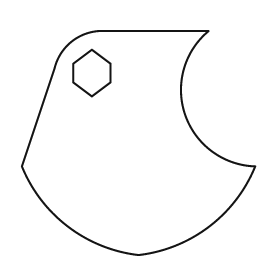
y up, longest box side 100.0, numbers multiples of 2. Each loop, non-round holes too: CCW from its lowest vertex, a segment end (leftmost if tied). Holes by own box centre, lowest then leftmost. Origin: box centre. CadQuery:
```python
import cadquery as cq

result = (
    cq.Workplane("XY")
    .moveTo(0.0, -48.0)
    .threePointArc((30.0, -36.0), (50.0, -10.0))
    .threePointArc((20.0, 12.0), (30.0, 48.0))
    .lineTo(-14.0, 48.0)
    .threePointArc((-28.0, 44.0), (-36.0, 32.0))
    .lineTo(-50.0, -10.0)
    .threePointArc((-30.0, -36.0), (0.0, -48.0))
    .close()
    .moveTo(-20.0, 20.0)
    .lineTo(-12.0, 26.0)
    .lineTo(-12.0, 34.0)
    .lineTo(-20.0, 40.0)
    .lineTo(-28.0, 34.0)
    .lineTo(-28.0, 26.0)
    .close()
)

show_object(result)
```